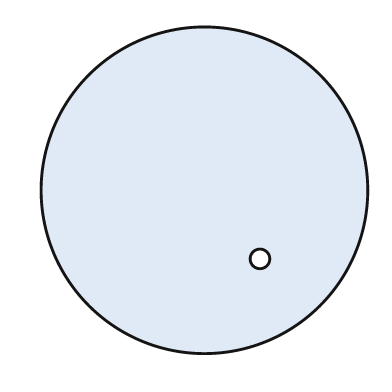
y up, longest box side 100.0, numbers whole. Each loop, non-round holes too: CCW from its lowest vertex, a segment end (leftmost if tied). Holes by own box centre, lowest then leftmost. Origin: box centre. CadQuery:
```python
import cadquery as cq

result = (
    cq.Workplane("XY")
    .moveTo(0.0, 0.0)
    .circle(50.0)
    .moveTo(17.0, -21.0)
    .circle(3.0)
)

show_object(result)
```